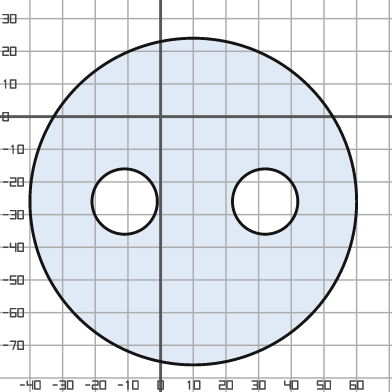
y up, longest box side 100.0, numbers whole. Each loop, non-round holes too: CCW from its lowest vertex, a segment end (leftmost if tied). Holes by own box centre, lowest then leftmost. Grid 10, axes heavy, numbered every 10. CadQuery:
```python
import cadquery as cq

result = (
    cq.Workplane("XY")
    .moveTo(10.0, -26.0)
    .circle(50.0)
    .moveTo(-11.0, -26.0)
    .circle(10.0)
    .moveTo(32.0, -26.0)
    .circle(10.0)
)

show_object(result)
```